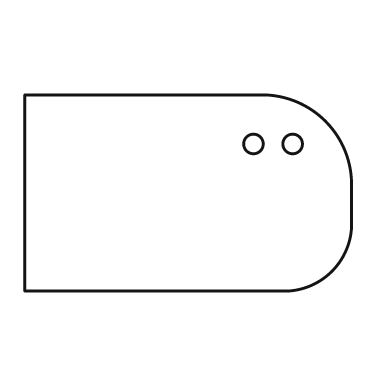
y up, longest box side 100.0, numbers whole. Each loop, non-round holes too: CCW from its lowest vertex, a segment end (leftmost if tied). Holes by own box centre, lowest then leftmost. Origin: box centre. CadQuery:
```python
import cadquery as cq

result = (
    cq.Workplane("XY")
    .moveTo(-50.0, -30.0)
    .lineTo(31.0, -30.0)
    .threePointArc((44.0, -24.0), (50.0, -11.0))
    .lineTo(50.0, 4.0)
    .threePointArc((42.0, 22.0), (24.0, 30.0))
    .lineTo(-50.0, 30.0)
    .close()
    .moveTo(20.0, 15.0)
    .circle(3.0)
    .moveTo(32.0, 15.0)
    .circle(3.0)
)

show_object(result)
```